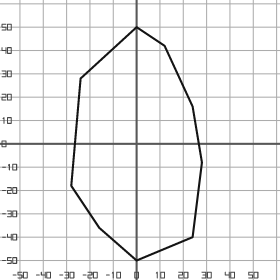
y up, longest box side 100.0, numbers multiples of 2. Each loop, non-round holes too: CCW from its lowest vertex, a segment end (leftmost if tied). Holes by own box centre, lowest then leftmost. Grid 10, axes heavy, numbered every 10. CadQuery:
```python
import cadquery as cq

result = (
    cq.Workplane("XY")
    .moveTo(0.0, -50.0)
    .lineTo(24.0, -40.0)
    .lineTo(28.0, -8.0)
    .lineTo(24.0, 16.0)
    .lineTo(12.0, 42.0)
    .lineTo(0.0, 50.0)
    .lineTo(-24.0, 28.0)
    .lineTo(-28.0, -18.0)
    .lineTo(-16.0, -36.0)
    .close()
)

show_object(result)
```